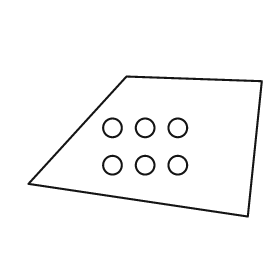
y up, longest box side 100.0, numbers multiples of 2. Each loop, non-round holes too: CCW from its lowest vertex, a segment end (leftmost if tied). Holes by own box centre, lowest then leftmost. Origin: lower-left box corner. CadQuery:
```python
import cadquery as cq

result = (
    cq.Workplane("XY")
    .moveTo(94.0, 0.0)
    .lineTo(100.0, 58.0)
    .lineTo(42.0, 60.0)
    .lineTo(0.0, 14.0)
    .close()
    .moveTo(36.0, 22.0)
    .circle(4.0)
    .moveTo(50.0, 22.0)
    .circle(4.0)
    .moveTo(64.0, 22.0)
    .circle(4.0)
    .moveTo(36.0, 38.0)
    .circle(4.0)
    .moveTo(50.0, 38.0)
    .circle(4.0)
    .moveTo(64.0, 38.0)
    .circle(4.0)
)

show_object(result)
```